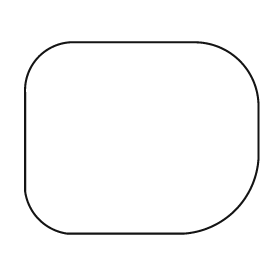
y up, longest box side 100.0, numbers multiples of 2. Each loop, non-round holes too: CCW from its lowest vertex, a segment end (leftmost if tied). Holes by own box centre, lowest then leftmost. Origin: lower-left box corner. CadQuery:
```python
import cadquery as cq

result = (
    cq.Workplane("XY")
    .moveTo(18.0, 0.0)
    .lineTo(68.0, 0.0)
    .threePointArc((90.0, 10.0), (100.0, 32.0))
    .lineTo(100.0, 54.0)
    .threePointArc((92.0, 74.0), (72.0, 82.0))
    .lineTo(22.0, 82.0)
    .threePointArc((6.0, 76.0), (0.0, 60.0))
    .lineTo(0.0, 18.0)
    .threePointArc((6.0, 6.0), (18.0, 0.0))
    .close()
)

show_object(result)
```